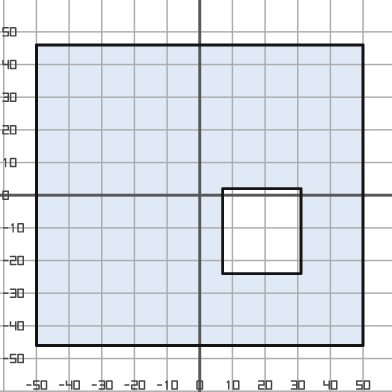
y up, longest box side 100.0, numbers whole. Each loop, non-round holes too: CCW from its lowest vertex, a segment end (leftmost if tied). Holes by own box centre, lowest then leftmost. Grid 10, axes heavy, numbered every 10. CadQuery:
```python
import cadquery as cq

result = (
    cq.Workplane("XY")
    .moveTo(-50.0, -46.0)
    .lineTo(50.0, -46.0)
    .lineTo(50.0, 46.0)
    .lineTo(-50.0, 46.0)
    .close()
    .moveTo(7.0, -24.0)
    .lineTo(31.0, -24.0)
    .lineTo(31.0, 2.0)
    .lineTo(7.0, 2.0)
    .close()
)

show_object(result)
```